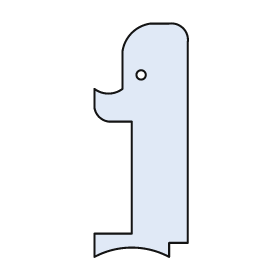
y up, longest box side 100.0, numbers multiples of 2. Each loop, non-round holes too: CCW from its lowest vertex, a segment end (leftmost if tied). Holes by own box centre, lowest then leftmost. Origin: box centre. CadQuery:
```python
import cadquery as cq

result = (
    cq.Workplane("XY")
    .moveTo(-20.0, -50.0)
    .threePointArc((-4.0, -46.0), (12.0, -50.0))
    .lineTo(12.0, -44.0)
    .lineTo(20.0, -44.0)
    .lineTo(20.0, 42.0)
    .threePointArc((18.0, 48.0), (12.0, 50.0))
    .lineTo(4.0, 50.0)
    .threePointArc((-4.0, 46.0), (-8.0, 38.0))
    .lineTo(-8.0, 22.0)
    .threePointArc((-14.0, 20.0), (-20.0, 22.0))
    .lineTo(-20.0, 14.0)
    .threePointArc((-18.0, 10.0), (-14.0, 8.0))
    .lineTo(-4.0, 8.0)
    .lineTo(-4.0, -40.0)
    .lineTo(-20.0, -40.0)
    .close()
    .moveTo(0.0, 28.0)
    .circle(2.0)
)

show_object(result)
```